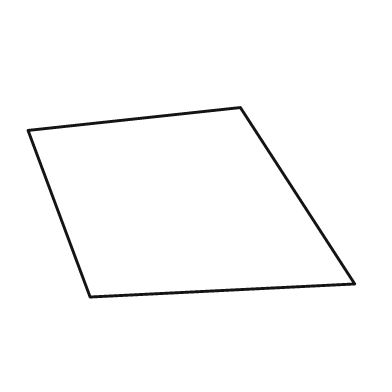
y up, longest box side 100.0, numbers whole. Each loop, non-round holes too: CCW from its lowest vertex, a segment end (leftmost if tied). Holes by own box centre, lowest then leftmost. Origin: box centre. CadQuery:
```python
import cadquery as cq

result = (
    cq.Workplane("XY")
    .moveTo(-31.0, -29.0)
    .lineTo(50.0, -25.0)
    .lineTo(15.0, 29.0)
    .lineTo(-50.0, 22.0)
    .close()
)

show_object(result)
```